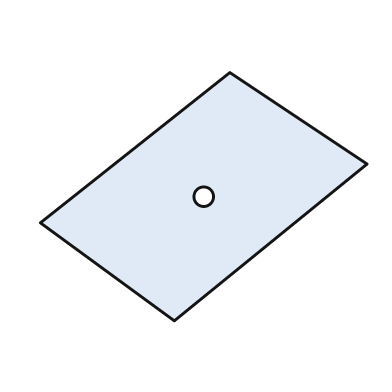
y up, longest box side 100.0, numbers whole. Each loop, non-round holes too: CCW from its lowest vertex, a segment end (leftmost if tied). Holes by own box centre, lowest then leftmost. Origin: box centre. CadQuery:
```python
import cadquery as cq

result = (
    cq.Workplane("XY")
    .moveTo(-9.0, -38.0)
    .lineTo(50.0, 10.0)
    .lineTo(8.0, 38.0)
    .lineTo(-50.0, -8.0)
    .close()
    .moveTo(0.0, 0.0)
    .circle(3.0)
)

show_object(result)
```